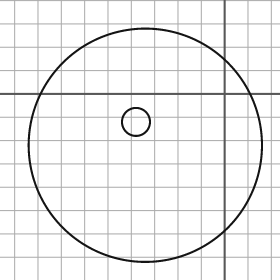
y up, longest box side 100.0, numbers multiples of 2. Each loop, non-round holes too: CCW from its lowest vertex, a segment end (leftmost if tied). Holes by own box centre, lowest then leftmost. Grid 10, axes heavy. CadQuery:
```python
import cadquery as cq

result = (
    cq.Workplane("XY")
    .moveTo(-34.0, -22.0)
    .circle(50.0)
    .moveTo(-38.0, -12.0)
    .circle(6.0)
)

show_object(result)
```